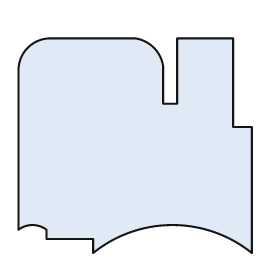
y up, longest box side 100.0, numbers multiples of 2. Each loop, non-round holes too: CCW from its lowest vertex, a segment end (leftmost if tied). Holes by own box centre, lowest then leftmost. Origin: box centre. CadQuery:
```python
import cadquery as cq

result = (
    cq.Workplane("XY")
    .moveTo(-18.0, -46.0)
    .threePointArc((16.0, -34.0), (50.0, -46.0))
    .lineTo(50.0, 8.0)
    .lineTo(42.0, 8.0)
    .lineTo(42.0, 46.0)
    .lineTo(18.0, 46.0)
    .lineTo(18.0, 18.0)
    .lineTo(12.0, 18.0)
    .lineTo(12.0, 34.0)
    .threePointArc((8.0, 42.0), (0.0, 46.0))
    .lineTo(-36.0, 46.0)
    .threePointArc((-46.0, 42.0), (-50.0, 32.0))
    .lineTo(-50.0, -36.0)
    .threePointArc((-44.0, -34.0), (-38.0, -36.0))
    .lineTo(-38.0, -40.0)
    .lineTo(-18.0, -40.0)
    .close()
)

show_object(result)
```